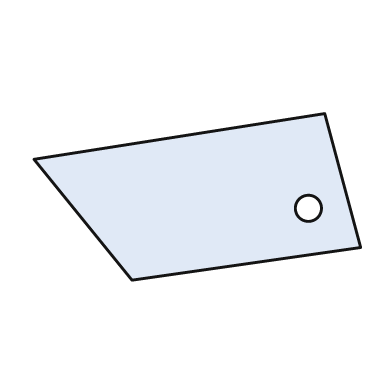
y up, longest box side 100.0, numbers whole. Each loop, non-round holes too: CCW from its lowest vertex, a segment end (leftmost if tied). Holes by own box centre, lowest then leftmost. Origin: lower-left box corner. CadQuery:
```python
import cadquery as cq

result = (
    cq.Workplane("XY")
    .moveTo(30.0, 0.0)
    .lineTo(100.0, 10.0)
    .lineTo(89.0, 51.0)
    .lineTo(0.0, 37.0)
    .close()
    .moveTo(84.0, 22.0)
    .circle(4.0)
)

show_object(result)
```